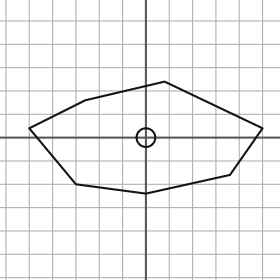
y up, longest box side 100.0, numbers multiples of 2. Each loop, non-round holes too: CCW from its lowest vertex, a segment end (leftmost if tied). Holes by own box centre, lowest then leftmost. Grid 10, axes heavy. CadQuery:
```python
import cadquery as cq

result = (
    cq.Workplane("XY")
    .moveTo(0.0, -24.0)
    .lineTo(36.0, -16.0)
    .lineTo(50.0, 4.0)
    .lineTo(8.0, 24.0)
    .lineTo(-26.0, 16.0)
    .lineTo(-50.0, 4.0)
    .lineTo(-30.0, -20.0)
    .close()
    .moveTo(0.0, 0.0)
    .circle(4.0)
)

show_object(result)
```